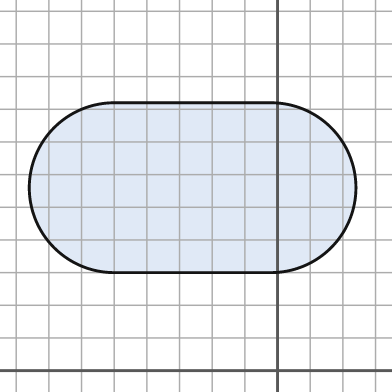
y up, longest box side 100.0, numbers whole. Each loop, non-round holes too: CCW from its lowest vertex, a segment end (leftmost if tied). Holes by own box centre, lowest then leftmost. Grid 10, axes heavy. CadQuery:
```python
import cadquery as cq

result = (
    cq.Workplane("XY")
    .moveTo(-50.0, 30.0)
    .lineTo(-2.0, 30.0)
    .threePointArc((24.0, 56.0), (-2.0, 82.0))
    .lineTo(-50.0, 82.0)
    .threePointArc((-76.0, 56.0), (-50.0, 30.0))
    .close()
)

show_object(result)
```